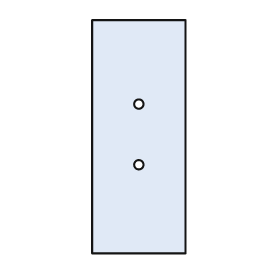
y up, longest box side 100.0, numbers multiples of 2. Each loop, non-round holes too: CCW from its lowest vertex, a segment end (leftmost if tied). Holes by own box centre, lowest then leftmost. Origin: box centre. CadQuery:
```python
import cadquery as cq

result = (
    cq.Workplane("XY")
    .moveTo(-20.0, -50.0)
    .lineTo(20.0, -50.0)
    .lineTo(20.0, 50.0)
    .lineTo(-20.0, 50.0)
    .close()
    .moveTo(0.0, -12.0)
    .circle(2.0)
    .moveTo(0.0, 14.0)
    .circle(2.0)
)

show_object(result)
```